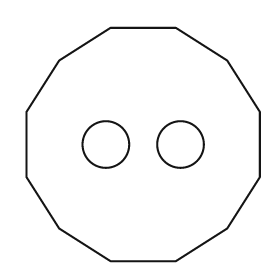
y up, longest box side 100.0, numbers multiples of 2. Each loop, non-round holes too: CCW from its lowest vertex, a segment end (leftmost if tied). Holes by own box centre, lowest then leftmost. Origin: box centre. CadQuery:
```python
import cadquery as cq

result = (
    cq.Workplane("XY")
    .moveTo(-14.0, -50.0)
    .lineTo(14.0, -50.0)
    .lineTo(36.0, -36.0)
    .lineTo(50.0, -14.0)
    .lineTo(50.0, 14.0)
    .lineTo(36.0, 36.0)
    .lineTo(14.0, 50.0)
    .lineTo(-14.0, 50.0)
    .lineTo(-36.0, 36.0)
    .lineTo(-50.0, 14.0)
    .lineTo(-50.0, -14.0)
    .lineTo(-36.0, -36.0)
    .close()
    .moveTo(-16.0, 0.0)
    .circle(10.0)
    .moveTo(16.0, 0.0)
    .circle(10.0)
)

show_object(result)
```